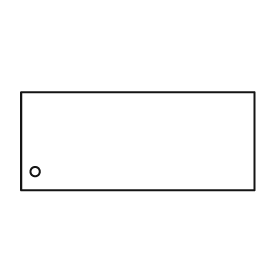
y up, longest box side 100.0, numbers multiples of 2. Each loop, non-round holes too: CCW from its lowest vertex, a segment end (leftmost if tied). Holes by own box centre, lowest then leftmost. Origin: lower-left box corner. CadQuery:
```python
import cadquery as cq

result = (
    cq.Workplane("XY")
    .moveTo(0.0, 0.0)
    .lineTo(100.0, 0.0)
    .lineTo(100.0, 42.0)
    .lineTo(0.0, 42.0)
    .close()
    .moveTo(6.0, 8.0)
    .circle(2.0)
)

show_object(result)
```